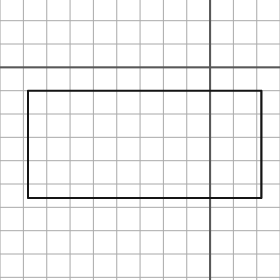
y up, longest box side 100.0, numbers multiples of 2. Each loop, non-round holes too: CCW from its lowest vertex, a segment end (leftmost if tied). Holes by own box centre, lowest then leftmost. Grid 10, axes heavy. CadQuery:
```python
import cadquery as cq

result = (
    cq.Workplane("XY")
    .moveTo(-78.0, -56.0)
    .lineTo(22.0, -56.0)
    .lineTo(22.0, -10.0)
    .lineTo(-78.0, -10.0)
    .close()
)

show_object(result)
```